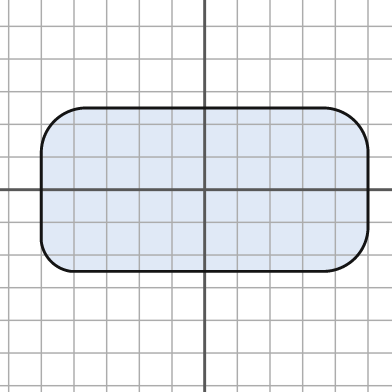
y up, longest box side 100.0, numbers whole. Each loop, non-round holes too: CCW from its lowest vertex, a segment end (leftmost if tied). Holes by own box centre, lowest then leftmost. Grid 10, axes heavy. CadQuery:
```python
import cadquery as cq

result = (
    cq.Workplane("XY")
    .moveTo(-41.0, -25.0)
    .lineTo(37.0, -25.0)
    .threePointArc((46.0, -21.0), (50.0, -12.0))
    .lineTo(50.0, 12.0)
    .threePointArc((46.0, 21.0), (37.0, 25.0))
    .lineTo(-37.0, 25.0)
    .threePointArc((-46.0, 21.0), (-50.0, 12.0))
    .lineTo(-50.0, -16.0)
    .threePointArc((-47.0, -22.0), (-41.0, -25.0))
    .close()
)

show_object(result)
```